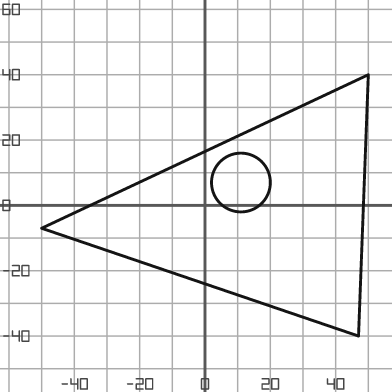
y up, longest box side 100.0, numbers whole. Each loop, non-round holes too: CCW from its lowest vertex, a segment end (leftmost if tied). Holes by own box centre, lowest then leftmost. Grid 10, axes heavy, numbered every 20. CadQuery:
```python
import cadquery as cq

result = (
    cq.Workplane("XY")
    .moveTo(47.0, -40.0)
    .lineTo(50.0, 40.0)
    .lineTo(-50.0, -7.0)
    .close()
    .moveTo(11.0, 7.0)
    .circle(9.0)
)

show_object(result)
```